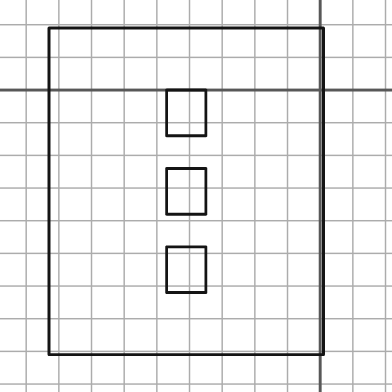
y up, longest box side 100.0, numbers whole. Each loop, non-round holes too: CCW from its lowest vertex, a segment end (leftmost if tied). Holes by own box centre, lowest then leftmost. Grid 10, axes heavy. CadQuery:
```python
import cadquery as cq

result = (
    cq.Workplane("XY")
    .moveTo(-83.0, -81.0)
    .lineTo(1.0, -81.0)
    .lineTo(1.0, 19.0)
    .lineTo(-83.0, 19.0)
    .close()
    .moveTo(-47.0, -62.0)
    .lineTo(-35.0, -62.0)
    .lineTo(-35.0, -48.0)
    .lineTo(-47.0, -48.0)
    .close()
    .moveTo(-47.0, -38.0)
    .lineTo(-35.0, -38.0)
    .lineTo(-35.0, -24.0)
    .lineTo(-47.0, -24.0)
    .close()
    .moveTo(-47.0, -14.0)
    .lineTo(-35.0, -14.0)
    .lineTo(-35.0, 0.0)
    .lineTo(-47.0, 0.0)
    .close()
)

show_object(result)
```